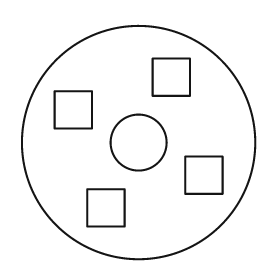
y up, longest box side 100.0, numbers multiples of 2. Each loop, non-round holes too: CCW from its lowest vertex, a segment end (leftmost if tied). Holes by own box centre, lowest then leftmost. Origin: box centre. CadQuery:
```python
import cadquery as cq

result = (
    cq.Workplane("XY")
    .moveTo(0.0, 0.0)
    .circle(50.0)
    .moveTo(-22.0, -36.0)
    .lineTo(-6.0, -36.0)
    .lineTo(-6.0, -20.0)
    .lineTo(-22.0, -20.0)
    .close()
    .moveTo(20.0, -22.0)
    .lineTo(36.0, -22.0)
    .lineTo(36.0, -6.0)
    .lineTo(20.0, -6.0)
    .close()
    .moveTo(0.0, 0.0)
    .circle(12.0)
    .moveTo(-36.0, 6.0)
    .lineTo(-20.0, 6.0)
    .lineTo(-20.0, 22.0)
    .lineTo(-36.0, 22.0)
    .close()
    .moveTo(6.0, 20.0)
    .lineTo(22.0, 20.0)
    .lineTo(22.0, 36.0)
    .lineTo(6.0, 36.0)
    .close()
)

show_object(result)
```